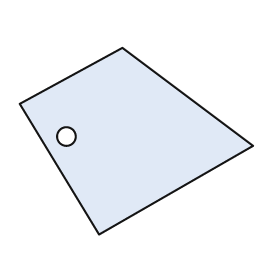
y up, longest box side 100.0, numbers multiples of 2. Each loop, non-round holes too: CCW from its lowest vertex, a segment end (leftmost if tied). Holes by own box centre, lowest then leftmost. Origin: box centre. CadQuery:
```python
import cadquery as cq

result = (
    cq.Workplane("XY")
    .moveTo(-16.0, -40.0)
    .lineTo(50.0, -2.0)
    .lineTo(-6.0, 40.0)
    .lineTo(-50.0, 16.0)
    .close()
    .moveTo(-30.0, 2.0)
    .circle(4.0)
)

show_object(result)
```